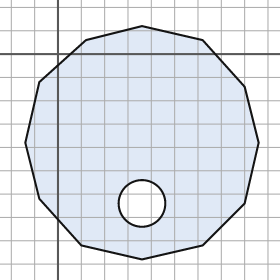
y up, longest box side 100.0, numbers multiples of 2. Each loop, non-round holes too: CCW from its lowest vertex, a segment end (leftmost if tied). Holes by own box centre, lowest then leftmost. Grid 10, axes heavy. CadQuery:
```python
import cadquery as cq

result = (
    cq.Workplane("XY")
    .moveTo(36.0, -88.0)
    .lineTo(62.0, -82.0)
    .lineTo(80.0, -64.0)
    .lineTo(86.0, -38.0)
    .lineTo(80.0, -14.0)
    .lineTo(62.0, 6.0)
    .lineTo(36.0, 12.0)
    .lineTo(12.0, 6.0)
    .lineTo(-8.0, -12.0)
    .lineTo(-14.0, -38.0)
    .lineTo(-8.0, -62.0)
    .lineTo(10.0, -82.0)
    .close()
    .moveTo(36.0, -64.0)
    .circle(10.0)
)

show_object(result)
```